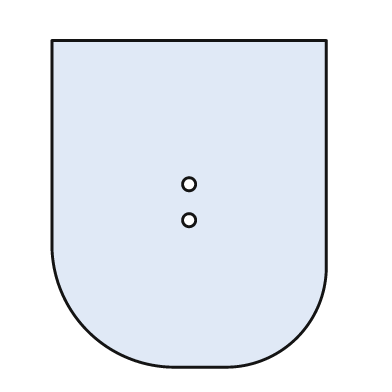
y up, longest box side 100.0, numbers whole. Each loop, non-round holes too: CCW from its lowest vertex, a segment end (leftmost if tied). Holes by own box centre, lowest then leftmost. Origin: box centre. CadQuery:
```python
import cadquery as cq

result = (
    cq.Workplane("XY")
    .moveTo(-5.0, -50.0)
    .lineTo(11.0, -50.0)
    .threePointArc((33.0, -41.0), (42.0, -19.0))
    .lineTo(42.0, 50.0)
    .lineTo(-42.0, 50.0)
    .lineTo(-42.0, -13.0)
    .threePointArc((-31.0, -39.0), (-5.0, -50.0))
    .close()
    .moveTo(0.0, -5.0)
    .circle(2.0)
    .moveTo(0.0, 6.0)
    .circle(2.0)
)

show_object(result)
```